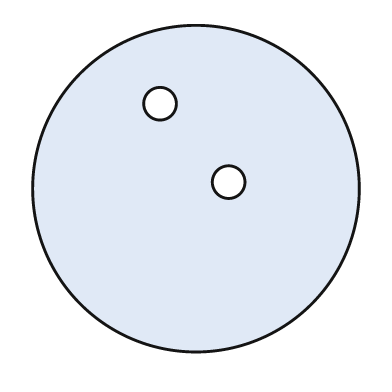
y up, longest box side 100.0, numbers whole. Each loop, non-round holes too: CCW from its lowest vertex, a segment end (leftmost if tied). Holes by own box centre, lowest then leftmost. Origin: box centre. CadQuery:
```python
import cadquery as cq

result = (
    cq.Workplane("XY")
    .moveTo(0.0, 0.0)
    .circle(50.0)
    .moveTo(10.0, 2.0)
    .circle(5.0)
    .moveTo(-11.0, 26.0)
    .circle(5.0)
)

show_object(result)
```